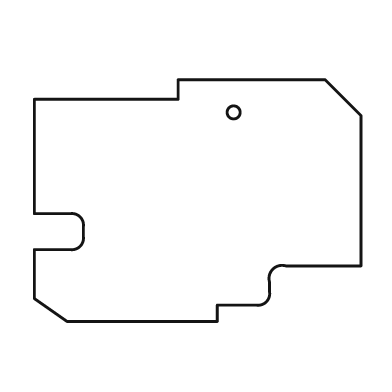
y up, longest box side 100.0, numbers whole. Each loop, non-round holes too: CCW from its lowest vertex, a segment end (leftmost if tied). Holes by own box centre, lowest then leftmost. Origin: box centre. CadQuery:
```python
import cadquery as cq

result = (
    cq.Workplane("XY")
    .moveTo(-40.0, -37.0)
    .lineTo(6.0, -37.0)
    .lineTo(6.0, -32.0)
    .lineTo(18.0, -32.0)
    .threePointArc((21.0, -31.0), (22.0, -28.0))
    .lineTo(22.0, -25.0)
    .threePointArc((23.0, -21.0), (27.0, -20.0))
    .lineTo(50.0, -20.0)
    .lineTo(50.0, 26.0)
    .lineTo(39.0, 37.0)
    .lineTo(-6.0, 37.0)
    .lineTo(-6.0, 31.0)
    .lineTo(-50.0, 31.0)
    .lineTo(-50.0, -4.0)
    .lineTo(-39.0, -4.0)
    .threePointArc((-36.0, -5.0), (-35.0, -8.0))
    .lineTo(-35.0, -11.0)
    .threePointArc((-36.0, -14.0), (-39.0, -15.0))
    .lineTo(-50.0, -15.0)
    .lineTo(-50.0, -30.0)
    .close()
    .moveTo(11.0, 27.0)
    .circle(2.0)
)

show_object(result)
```